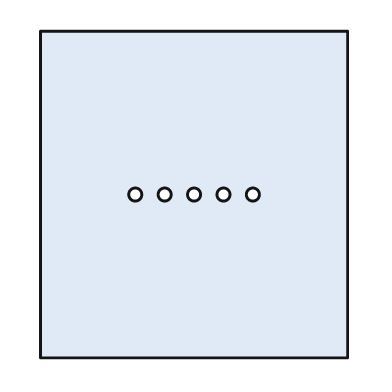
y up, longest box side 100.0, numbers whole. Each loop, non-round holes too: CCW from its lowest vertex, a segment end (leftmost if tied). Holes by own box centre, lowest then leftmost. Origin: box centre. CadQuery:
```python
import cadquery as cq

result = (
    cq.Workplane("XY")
    .moveTo(-47.0, -50.0)
    .lineTo(47.0, -50.0)
    .lineTo(47.0, 50.0)
    .lineTo(-47.0, 50.0)
    .close()
    .moveTo(-18.0, 0.0)
    .circle(2.0)
    .moveTo(-9.0, 0.0)
    .circle(2.0)
    .moveTo(0.0, 0.0)
    .circle(2.0)
    .moveTo(9.0, 0.0)
    .circle(2.0)
    .moveTo(18.0, 0.0)
    .circle(2.0)
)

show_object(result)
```